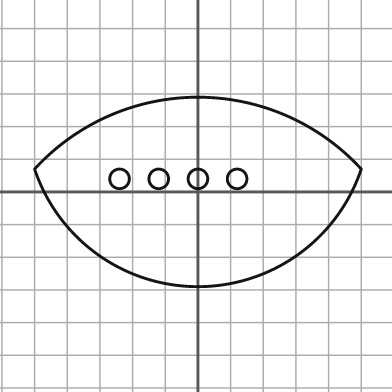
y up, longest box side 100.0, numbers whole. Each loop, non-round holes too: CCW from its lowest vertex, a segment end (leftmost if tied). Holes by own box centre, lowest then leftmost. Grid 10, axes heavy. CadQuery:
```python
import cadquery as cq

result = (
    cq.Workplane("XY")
    .moveTo(-50.0, 7.0)
    .threePointArc((0.0, -29.0), (50.0, 7.0))
    .threePointArc((0.0, 29.0), (-50.0, 7.0))
    .close()
    .moveTo(-24.0, 4.0)
    .circle(3.0)
    .moveTo(-12.0, 4.0)
    .circle(3.0)
    .moveTo(0.0, 4.0)
    .circle(3.0)
    .moveTo(12.0, 4.0)
    .circle(3.0)
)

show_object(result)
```